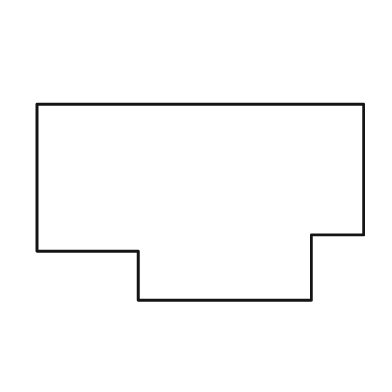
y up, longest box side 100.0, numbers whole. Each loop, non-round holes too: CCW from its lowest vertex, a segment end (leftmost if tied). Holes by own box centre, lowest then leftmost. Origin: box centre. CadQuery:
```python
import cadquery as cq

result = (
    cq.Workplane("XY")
    .moveTo(-19.0, -30.0)
    .lineTo(34.0, -30.0)
    .lineTo(34.0, -10.0)
    .lineTo(50.0, -10.0)
    .lineTo(50.0, 30.0)
    .lineTo(-50.0, 30.0)
    .lineTo(-50.0, -15.0)
    .lineTo(-19.0, -15.0)
    .close()
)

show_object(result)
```